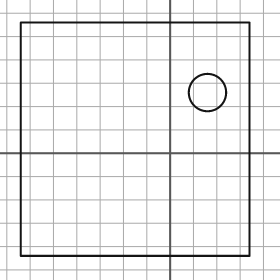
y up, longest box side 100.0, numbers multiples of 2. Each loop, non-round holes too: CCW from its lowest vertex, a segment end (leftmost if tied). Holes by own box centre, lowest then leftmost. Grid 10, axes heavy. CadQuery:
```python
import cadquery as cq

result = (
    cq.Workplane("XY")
    .moveTo(-64.0, -44.0)
    .lineTo(34.0, -44.0)
    .lineTo(34.0, 56.0)
    .lineTo(-64.0, 56.0)
    .close()
    .moveTo(16.0, 26.0)
    .circle(8.0)
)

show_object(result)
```